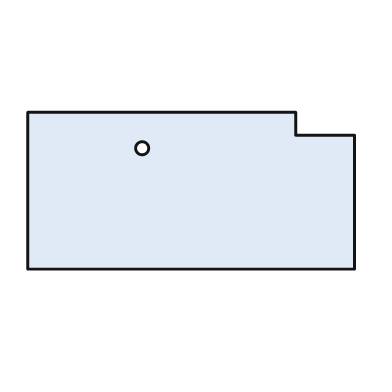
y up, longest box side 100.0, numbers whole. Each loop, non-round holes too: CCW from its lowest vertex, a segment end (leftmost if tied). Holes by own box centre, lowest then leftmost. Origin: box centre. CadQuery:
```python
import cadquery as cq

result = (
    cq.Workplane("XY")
    .moveTo(-50.0, -24.0)
    .lineTo(50.0, -24.0)
    .lineTo(50.0, 17.0)
    .lineTo(32.0, 17.0)
    .lineTo(32.0, 24.0)
    .lineTo(-50.0, 24.0)
    .close()
    .moveTo(-15.0, 13.0)
    .circle(2.0)
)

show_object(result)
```